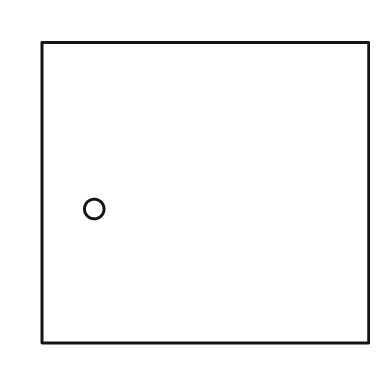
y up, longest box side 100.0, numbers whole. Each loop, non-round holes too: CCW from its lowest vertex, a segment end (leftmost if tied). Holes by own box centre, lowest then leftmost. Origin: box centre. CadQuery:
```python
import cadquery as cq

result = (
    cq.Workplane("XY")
    .moveTo(-50.0, -46.0)
    .lineTo(50.0, -46.0)
    .lineTo(50.0, 46.0)
    .lineTo(-50.0, 46.0)
    .close()
    .moveTo(-34.0, -5.0)
    .circle(3.0)
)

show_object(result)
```